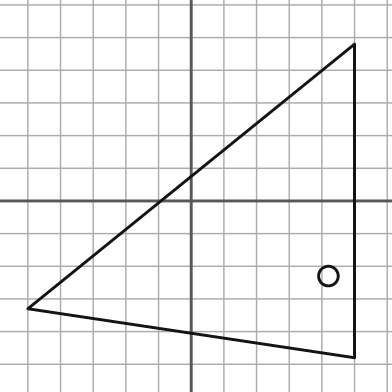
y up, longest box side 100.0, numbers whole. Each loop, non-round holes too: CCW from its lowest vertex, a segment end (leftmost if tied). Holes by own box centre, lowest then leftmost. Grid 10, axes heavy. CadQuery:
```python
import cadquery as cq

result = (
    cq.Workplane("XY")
    .moveTo(50.0, -48.0)
    .lineTo(50.0, 48.0)
    .lineTo(-50.0, -33.0)
    .close()
    .moveTo(42.0, -23.0)
    .circle(3.0)
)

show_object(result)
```